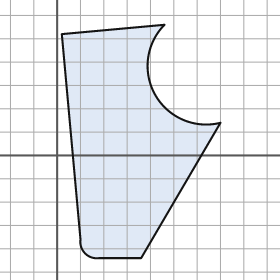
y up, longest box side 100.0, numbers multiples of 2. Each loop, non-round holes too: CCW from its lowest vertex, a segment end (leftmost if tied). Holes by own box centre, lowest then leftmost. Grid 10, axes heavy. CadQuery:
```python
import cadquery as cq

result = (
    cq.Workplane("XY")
    .moveTo(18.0, -44.0)
    .lineTo(36.0, -44.0)
    .lineTo(70.0, 14.0)
    .threePointArc((42.0, 26.0), (46.0, 56.0))
    .lineTo(2.0, 52.0)
    .lineTo(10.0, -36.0)
    .threePointArc((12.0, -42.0), (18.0, -44.0))
    .close()
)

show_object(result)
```